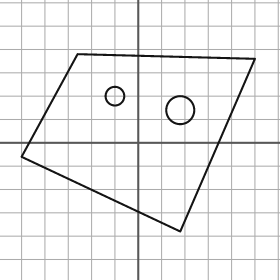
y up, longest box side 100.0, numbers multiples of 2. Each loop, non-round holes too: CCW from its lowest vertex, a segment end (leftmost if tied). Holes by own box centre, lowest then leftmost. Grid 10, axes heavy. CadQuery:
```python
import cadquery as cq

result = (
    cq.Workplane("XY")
    .moveTo(18.0, -38.0)
    .lineTo(50.0, 36.0)
    .lineTo(-26.0, 38.0)
    .lineTo(-50.0, -6.0)
    .close()
    .moveTo(18.0, 14.0)
    .circle(6.0)
    .moveTo(-10.0, 20.0)
    .circle(4.0)
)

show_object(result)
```